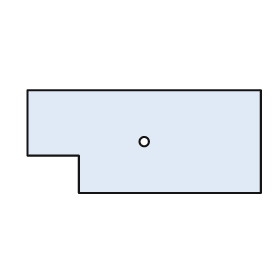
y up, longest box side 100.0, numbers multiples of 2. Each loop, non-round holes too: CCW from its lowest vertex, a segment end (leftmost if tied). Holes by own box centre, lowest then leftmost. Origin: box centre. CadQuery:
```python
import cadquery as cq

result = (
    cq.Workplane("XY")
    .moveTo(-28.0, -22.0)
    .lineTo(50.0, -22.0)
    .lineTo(50.0, 22.0)
    .lineTo(-50.0, 22.0)
    .lineTo(-50.0, -6.0)
    .lineTo(-28.0, -6.0)
    .close()
    .moveTo(0.0, 0.0)
    .circle(2.0)
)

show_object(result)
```